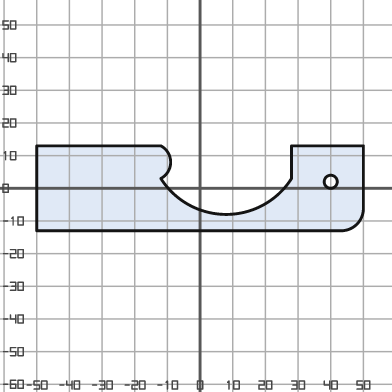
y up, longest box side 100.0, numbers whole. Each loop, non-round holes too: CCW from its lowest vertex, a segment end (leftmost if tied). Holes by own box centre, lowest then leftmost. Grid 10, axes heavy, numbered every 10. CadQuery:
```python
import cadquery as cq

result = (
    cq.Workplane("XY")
    .moveTo(-50.0, -13.0)
    .lineTo(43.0, -13.0)
    .threePointArc((48.0, -11.0), (50.0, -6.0))
    .lineTo(50.0, 13.0)
    .lineTo(28.0, 13.0)
    .lineTo(28.0, 3.0)
    .threePointArc((8.0, -8.0), (-12.0, 3.0))
    .threePointArc((-9.0, 8.0), (-12.0, 13.0))
    .lineTo(-50.0, 13.0)
    .close()
    .moveTo(40.0, 2.0)
    .circle(2.0)
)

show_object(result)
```